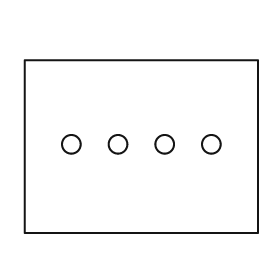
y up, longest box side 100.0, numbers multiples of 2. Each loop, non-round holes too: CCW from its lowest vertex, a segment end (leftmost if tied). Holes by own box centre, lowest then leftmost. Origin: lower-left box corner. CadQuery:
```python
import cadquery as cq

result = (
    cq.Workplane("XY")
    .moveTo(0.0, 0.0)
    .lineTo(100.0, 0.0)
    .lineTo(100.0, 74.0)
    .lineTo(0.0, 74.0)
    .close()
    .moveTo(20.0, 38.0)
    .circle(4.0)
    .moveTo(40.0, 38.0)
    .circle(4.0)
    .moveTo(60.0, 38.0)
    .circle(4.0)
    .moveTo(80.0, 38.0)
    .circle(4.0)
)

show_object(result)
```